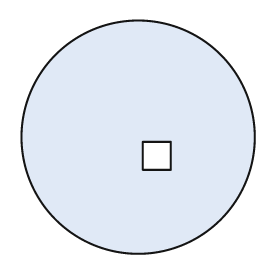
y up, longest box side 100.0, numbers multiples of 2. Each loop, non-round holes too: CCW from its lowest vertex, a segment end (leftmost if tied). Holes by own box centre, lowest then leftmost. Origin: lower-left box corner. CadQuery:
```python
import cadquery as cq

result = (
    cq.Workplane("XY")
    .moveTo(50.0, 50.0)
    .circle(50.0)
    .moveTo(52.0, 36.0)
    .lineTo(64.0, 36.0)
    .lineTo(64.0, 48.0)
    .lineTo(52.0, 48.0)
    .close()
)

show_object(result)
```